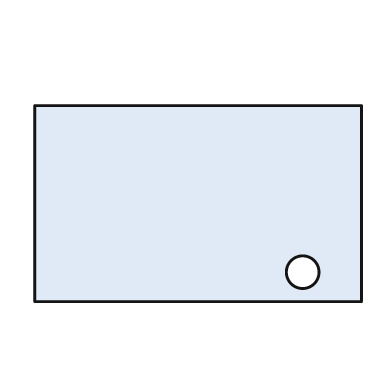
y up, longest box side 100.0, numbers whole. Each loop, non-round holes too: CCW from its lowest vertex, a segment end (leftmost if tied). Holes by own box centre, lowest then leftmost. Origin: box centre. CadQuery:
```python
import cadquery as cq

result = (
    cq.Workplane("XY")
    .moveTo(-50.0, -30.0)
    .lineTo(50.0, -30.0)
    .lineTo(50.0, 30.0)
    .lineTo(-50.0, 30.0)
    .close()
    .moveTo(32.0, -21.0)
    .circle(5.0)
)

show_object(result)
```